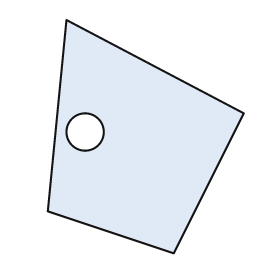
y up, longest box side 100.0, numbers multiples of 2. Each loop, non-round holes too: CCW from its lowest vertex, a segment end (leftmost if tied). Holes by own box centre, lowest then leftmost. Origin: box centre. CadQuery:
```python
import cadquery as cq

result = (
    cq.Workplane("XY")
    .moveTo(12.0, -50.0)
    .lineTo(42.0, 10.0)
    .lineTo(-34.0, 50.0)
    .lineTo(-42.0, -32.0)
    .close()
    .moveTo(-26.0, 2.0)
    .circle(8.0)
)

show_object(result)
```